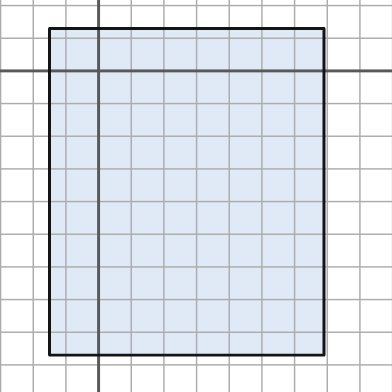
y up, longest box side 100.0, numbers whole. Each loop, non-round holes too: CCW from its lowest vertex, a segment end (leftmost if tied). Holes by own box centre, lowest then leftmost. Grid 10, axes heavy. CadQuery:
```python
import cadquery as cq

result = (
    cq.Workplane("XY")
    .moveTo(-15.0, -87.0)
    .lineTo(69.0, -87.0)
    .lineTo(69.0, 13.0)
    .lineTo(-15.0, 13.0)
    .close()
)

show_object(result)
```